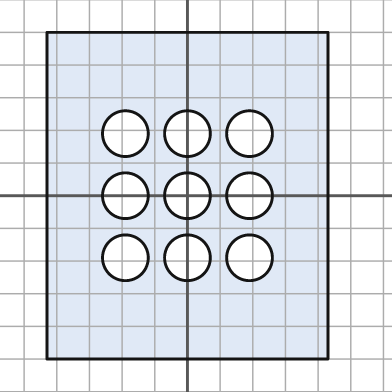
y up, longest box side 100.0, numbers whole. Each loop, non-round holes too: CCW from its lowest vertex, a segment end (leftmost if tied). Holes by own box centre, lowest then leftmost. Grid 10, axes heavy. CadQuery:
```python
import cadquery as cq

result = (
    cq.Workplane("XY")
    .moveTo(-43.0, -50.0)
    .lineTo(43.0, -50.0)
    .lineTo(43.0, 50.0)
    .lineTo(-43.0, 50.0)
    .close()
    .moveTo(-19.0, -19.0)
    .circle(7.0)
    .moveTo(0.0, -19.0)
    .circle(7.0)
    .moveTo(19.0, -19.0)
    .circle(7.0)
    .moveTo(-19.0, 0.0)
    .circle(7.0)
    .moveTo(0.0, 0.0)
    .circle(7.0)
    .moveTo(19.0, 0.0)
    .circle(7.0)
    .moveTo(-19.0, 19.0)
    .circle(7.0)
    .moveTo(0.0, 19.0)
    .circle(7.0)
    .moveTo(19.0, 19.0)
    .circle(7.0)
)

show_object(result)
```